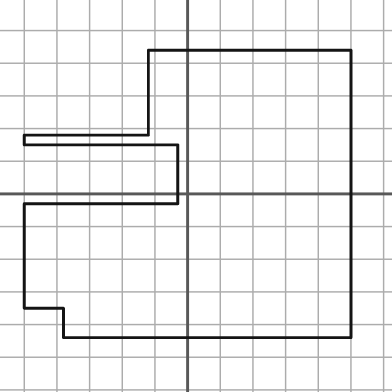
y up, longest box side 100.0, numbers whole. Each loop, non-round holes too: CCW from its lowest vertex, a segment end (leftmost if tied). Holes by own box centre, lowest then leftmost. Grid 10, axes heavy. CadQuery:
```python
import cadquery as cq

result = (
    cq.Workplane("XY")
    .moveTo(-38.0, -44.0)
    .lineTo(50.0, -44.0)
    .lineTo(50.0, 44.0)
    .lineTo(-12.0, 44.0)
    .lineTo(-12.0, 18.0)
    .lineTo(-50.0, 18.0)
    .lineTo(-50.0, 15.0)
    .lineTo(-3.0, 15.0)
    .lineTo(-3.0, -3.0)
    .lineTo(-50.0, -3.0)
    .lineTo(-50.0, -35.0)
    .lineTo(-38.0, -35.0)
    .close()
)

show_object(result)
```